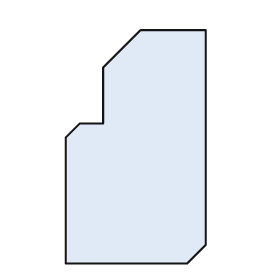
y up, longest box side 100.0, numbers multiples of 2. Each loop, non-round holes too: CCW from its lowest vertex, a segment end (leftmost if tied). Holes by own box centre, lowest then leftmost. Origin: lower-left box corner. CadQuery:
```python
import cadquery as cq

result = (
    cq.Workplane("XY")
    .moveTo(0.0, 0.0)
    .lineTo(52.0, 0.0)
    .lineTo(60.0, 8.0)
    .lineTo(60.0, 100.0)
    .lineTo(32.0, 100.0)
    .lineTo(16.0, 84.0)
    .lineTo(16.0, 60.0)
    .lineTo(6.0, 60.0)
    .lineTo(0.0, 54.0)
    .close()
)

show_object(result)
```